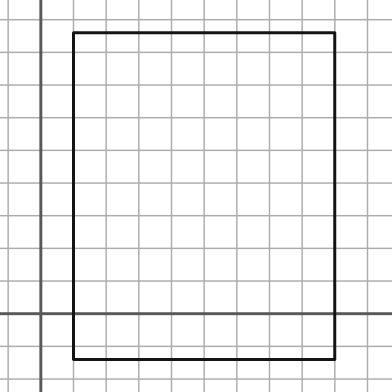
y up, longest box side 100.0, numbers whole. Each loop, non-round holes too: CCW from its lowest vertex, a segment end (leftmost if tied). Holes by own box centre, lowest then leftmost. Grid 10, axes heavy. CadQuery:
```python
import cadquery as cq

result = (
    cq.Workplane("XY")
    .moveTo(10.0, -14.0)
    .lineTo(90.0, -14.0)
    .lineTo(90.0, 86.0)
    .lineTo(10.0, 86.0)
    .close()
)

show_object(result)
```